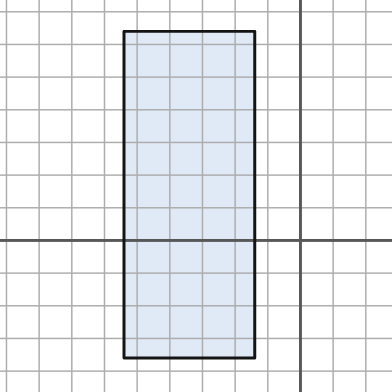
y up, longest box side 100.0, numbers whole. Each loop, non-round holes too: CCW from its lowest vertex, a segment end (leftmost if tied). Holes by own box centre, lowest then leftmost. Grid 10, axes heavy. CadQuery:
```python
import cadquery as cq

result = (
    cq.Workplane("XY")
    .moveTo(-54.0, -36.0)
    .lineTo(-14.0, -36.0)
    .lineTo(-14.0, 64.0)
    .lineTo(-54.0, 64.0)
    .close()
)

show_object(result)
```